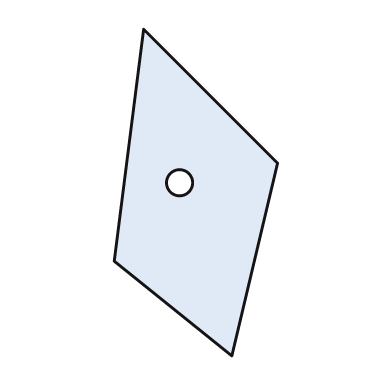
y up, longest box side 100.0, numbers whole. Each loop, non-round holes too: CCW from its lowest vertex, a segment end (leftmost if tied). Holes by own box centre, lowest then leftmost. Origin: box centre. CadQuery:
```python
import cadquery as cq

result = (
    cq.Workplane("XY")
    .moveTo(11.0, -50.0)
    .lineTo(25.0, 9.0)
    .lineTo(-16.0, 50.0)
    .lineTo(-25.0, -21.0)
    .close()
    .moveTo(-5.0, 3.0)
    .circle(4.0)
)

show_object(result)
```